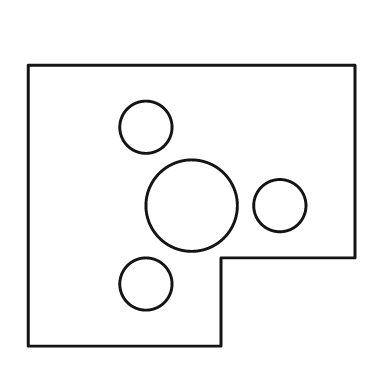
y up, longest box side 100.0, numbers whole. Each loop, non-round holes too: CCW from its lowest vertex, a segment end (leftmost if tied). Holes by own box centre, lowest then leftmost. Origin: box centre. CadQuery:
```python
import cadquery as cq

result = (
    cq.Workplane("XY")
    .moveTo(-50.0, -43.0)
    .lineTo(9.0, -43.0)
    .lineTo(9.0, -16.0)
    .lineTo(50.0, -16.0)
    .lineTo(50.0, 43.0)
    .lineTo(-50.0, 43.0)
    .close()
    .moveTo(-14.0, -24.0)
    .circle(8.0)
    .moveTo(0.0, 0.0)
    .circle(14.0)
    .moveTo(27.0, 0.0)
    .circle(8.0)
    .moveTo(-14.0, 24.0)
    .circle(8.0)
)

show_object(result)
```